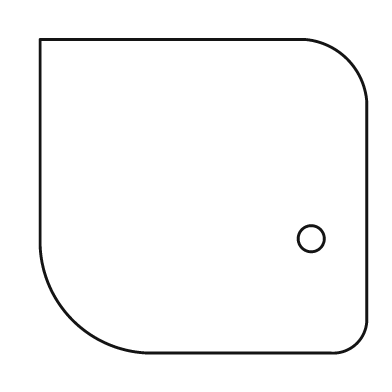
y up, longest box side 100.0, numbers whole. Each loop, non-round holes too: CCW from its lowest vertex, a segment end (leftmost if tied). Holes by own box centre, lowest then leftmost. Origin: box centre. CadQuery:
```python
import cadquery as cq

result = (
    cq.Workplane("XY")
    .moveTo(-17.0, -48.0)
    .lineTo(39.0, -48.0)
    .threePointArc((47.0, -45.0), (50.0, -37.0))
    .lineTo(50.0, 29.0)
    .threePointArc((44.0, 42.0), (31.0, 48.0))
    .lineTo(-50.0, 48.0)
    .lineTo(-50.0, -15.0)
    .threePointArc((-40.0, -38.0), (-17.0, -48.0))
    .close()
    .moveTo(33.0, -13.0)
    .circle(4.0)
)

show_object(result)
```